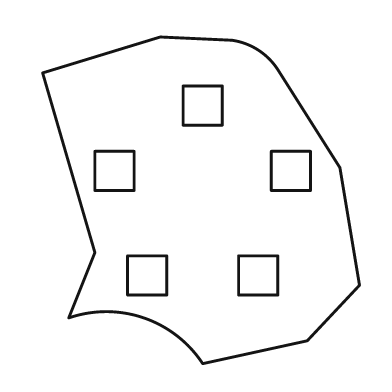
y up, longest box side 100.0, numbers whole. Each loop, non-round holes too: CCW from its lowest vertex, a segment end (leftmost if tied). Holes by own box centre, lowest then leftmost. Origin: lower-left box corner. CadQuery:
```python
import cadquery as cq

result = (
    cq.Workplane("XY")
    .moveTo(49.0, 0.0)
    .lineTo(81.0, 7.0)
    .lineTo(97.0, 24.0)
    .lineTo(91.0, 60.0)
    .lineTo(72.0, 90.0)
    .threePointArc((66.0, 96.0), (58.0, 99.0))
    .lineTo(36.0, 100.0)
    .lineTo(0.0, 89.0)
    .lineTo(16.0, 34.0)
    .lineTo(8.0, 14.0)
    .threePointArc((31.0, 14.0), (49.0, 0.0))
    .close()
    .moveTo(26.0, 21.0)
    .lineTo(38.0, 21.0)
    .lineTo(38.0, 33.0)
    .lineTo(26.0, 33.0)
    .close()
    .moveTo(60.0, 21.0)
    .lineTo(72.0, 21.0)
    .lineTo(72.0, 33.0)
    .lineTo(60.0, 33.0)
    .close()
    .moveTo(16.0, 53.0)
    .lineTo(28.0, 53.0)
    .lineTo(28.0, 65.0)
    .lineTo(16.0, 65.0)
    .close()
    .moveTo(70.0, 53.0)
    .lineTo(82.0, 53.0)
    .lineTo(82.0, 65.0)
    .lineTo(70.0, 65.0)
    .close()
    .moveTo(43.0, 73.0)
    .lineTo(55.0, 73.0)
    .lineTo(55.0, 85.0)
    .lineTo(43.0, 85.0)
    .close()
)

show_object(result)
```